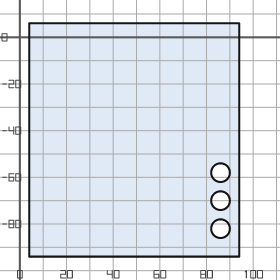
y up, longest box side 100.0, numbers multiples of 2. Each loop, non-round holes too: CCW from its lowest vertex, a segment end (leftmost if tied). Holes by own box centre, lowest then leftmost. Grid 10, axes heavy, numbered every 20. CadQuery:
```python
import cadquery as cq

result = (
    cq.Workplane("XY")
    .moveTo(4.0, -94.0)
    .lineTo(94.0, -94.0)
    .lineTo(94.0, 6.0)
    .lineTo(4.0, 6.0)
    .close()
    .moveTo(86.0, -82.0)
    .circle(4.0)
    .moveTo(86.0, -70.0)
    .circle(4.0)
    .moveTo(86.0, -58.0)
    .circle(4.0)
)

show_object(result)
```